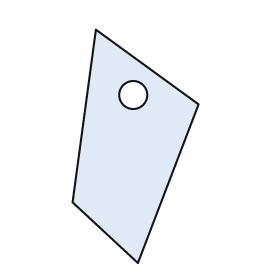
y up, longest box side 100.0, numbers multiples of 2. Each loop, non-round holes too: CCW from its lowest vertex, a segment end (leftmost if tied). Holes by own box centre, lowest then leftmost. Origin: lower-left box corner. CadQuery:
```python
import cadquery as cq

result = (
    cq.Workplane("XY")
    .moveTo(28.0, 0.0)
    .lineTo(54.0, 68.0)
    .lineTo(10.0, 100.0)
    .lineTo(0.0, 26.0)
    .close()
    .moveTo(26.0, 72.0)
    .circle(6.0)
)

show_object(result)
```